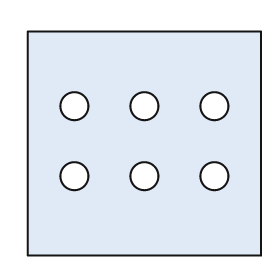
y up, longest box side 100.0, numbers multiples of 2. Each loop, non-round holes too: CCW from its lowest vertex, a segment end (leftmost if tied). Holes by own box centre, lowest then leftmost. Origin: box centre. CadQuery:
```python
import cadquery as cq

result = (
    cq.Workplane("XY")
    .moveTo(-50.0, -48.0)
    .lineTo(50.0, -48.0)
    .lineTo(50.0, 48.0)
    .lineTo(-50.0, 48.0)
    .close()
    .moveTo(-30.0, -14.0)
    .circle(6.0)
    .moveTo(0.0, -14.0)
    .circle(6.0)
    .moveTo(30.0, -14.0)
    .circle(6.0)
    .moveTo(-30.0, 16.0)
    .circle(6.0)
    .moveTo(0.0, 16.0)
    .circle(6.0)
    .moveTo(30.0, 16.0)
    .circle(6.0)
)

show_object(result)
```